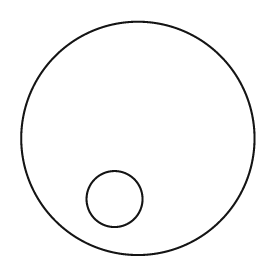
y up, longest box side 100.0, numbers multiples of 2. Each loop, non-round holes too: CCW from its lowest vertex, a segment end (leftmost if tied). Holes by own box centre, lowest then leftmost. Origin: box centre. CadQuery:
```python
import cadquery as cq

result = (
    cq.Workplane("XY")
    .moveTo(0.0, 0.0)
    .circle(50.0)
    .moveTo(-10.0, -26.0)
    .circle(12.0)
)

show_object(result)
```